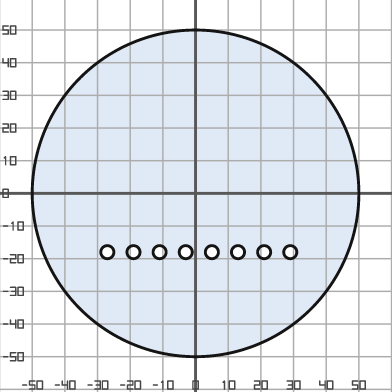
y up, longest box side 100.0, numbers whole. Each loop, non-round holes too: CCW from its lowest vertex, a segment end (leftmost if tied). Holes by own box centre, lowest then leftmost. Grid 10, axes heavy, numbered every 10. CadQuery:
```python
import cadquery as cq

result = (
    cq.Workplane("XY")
    .moveTo(0.0, 0.0)
    .circle(50.0)
    .moveTo(-27.0, -18.0)
    .circle(2.0)
    .moveTo(-19.0, -18.0)
    .circle(2.0)
    .moveTo(-11.0, -18.0)
    .circle(2.0)
    .moveTo(-3.0, -18.0)
    .circle(2.0)
    .moveTo(5.0, -18.0)
    .circle(2.0)
    .moveTo(13.0, -18.0)
    .circle(2.0)
    .moveTo(21.0, -18.0)
    .circle(2.0)
    .moveTo(29.0, -18.0)
    .circle(2.0)
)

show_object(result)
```